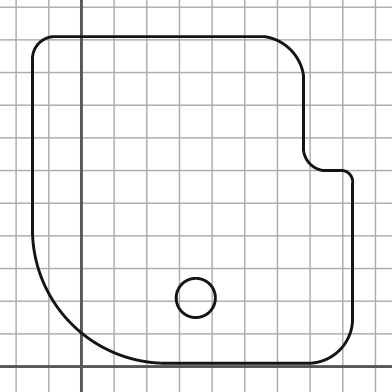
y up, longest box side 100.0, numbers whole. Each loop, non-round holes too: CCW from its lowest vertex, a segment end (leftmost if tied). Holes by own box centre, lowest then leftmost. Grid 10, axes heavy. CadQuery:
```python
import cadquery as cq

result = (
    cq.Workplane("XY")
    .moveTo(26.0, 1.0)
    .lineTo(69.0, 1.0)
    .threePointArc((79.0, 5.0), (83.0, 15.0))
    .lineTo(83.0, 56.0)
    .threePointArc((82.0, 59.0), (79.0, 60.0))
    .lineTo(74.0, 60.0)
    .threePointArc((70.0, 62.0), (68.0, 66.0))
    .lineTo(68.0, 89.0)
    .threePointArc((64.0, 97.0), (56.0, 101.0))
    .lineTo(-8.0, 101.0)
    .threePointArc((-13.0, 99.0), (-15.0, 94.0))
    .lineTo(-15.0, 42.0)
    .threePointArc((-3.0, 13.0), (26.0, 1.0))
    .close()
    .moveTo(35.0, 21.0)
    .circle(6.0)
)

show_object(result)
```